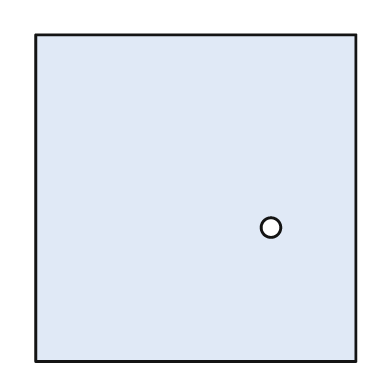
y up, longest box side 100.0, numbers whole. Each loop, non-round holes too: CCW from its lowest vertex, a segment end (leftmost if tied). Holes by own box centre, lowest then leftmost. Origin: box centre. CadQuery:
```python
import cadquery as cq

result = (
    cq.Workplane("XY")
    .moveTo(-49.0, -50.0)
    .lineTo(49.0, -50.0)
    .lineTo(49.0, 50.0)
    .lineTo(-49.0, 50.0)
    .close()
    .moveTo(23.0, -9.0)
    .circle(3.0)
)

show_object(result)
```